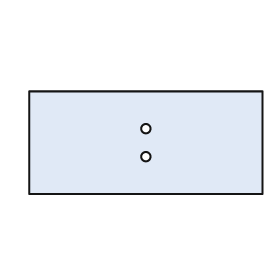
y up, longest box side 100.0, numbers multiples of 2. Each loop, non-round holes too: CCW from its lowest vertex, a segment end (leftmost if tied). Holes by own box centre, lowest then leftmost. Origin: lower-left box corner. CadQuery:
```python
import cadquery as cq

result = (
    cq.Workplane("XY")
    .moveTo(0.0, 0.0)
    .lineTo(100.0, 0.0)
    .lineTo(100.0, 44.0)
    .lineTo(0.0, 44.0)
    .close()
    .moveTo(50.0, 16.0)
    .circle(2.0)
    .moveTo(50.0, 28.0)
    .circle(2.0)
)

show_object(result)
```